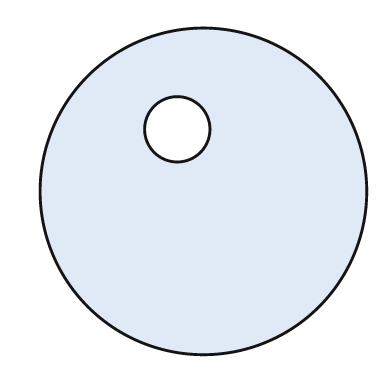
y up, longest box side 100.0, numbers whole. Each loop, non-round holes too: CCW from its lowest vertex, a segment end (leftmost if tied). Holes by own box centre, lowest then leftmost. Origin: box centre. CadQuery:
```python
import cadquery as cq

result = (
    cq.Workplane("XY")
    .moveTo(0.0, 0.0)
    .circle(50.0)
    .moveTo(-8.0, 19.0)
    .circle(10.0)
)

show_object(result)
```